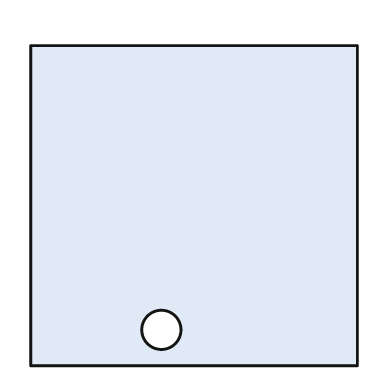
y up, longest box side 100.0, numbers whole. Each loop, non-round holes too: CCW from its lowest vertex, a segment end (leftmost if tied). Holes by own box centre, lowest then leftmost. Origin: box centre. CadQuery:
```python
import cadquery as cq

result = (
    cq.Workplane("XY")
    .moveTo(-50.0, -49.0)
    .lineTo(50.0, -49.0)
    .lineTo(50.0, 49.0)
    .lineTo(-50.0, 49.0)
    .close()
    .moveTo(-10.0, -38.0)
    .circle(6.0)
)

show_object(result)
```